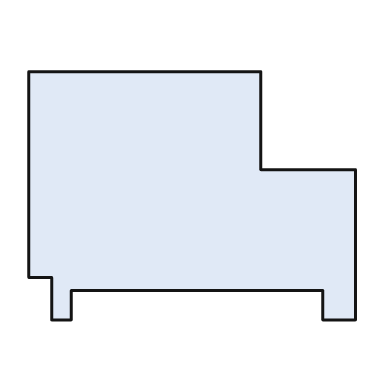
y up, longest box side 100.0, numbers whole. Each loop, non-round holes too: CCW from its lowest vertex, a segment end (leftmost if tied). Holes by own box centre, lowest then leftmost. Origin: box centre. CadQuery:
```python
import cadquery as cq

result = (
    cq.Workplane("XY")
    .moveTo(-43.0, -38.0)
    .lineTo(-37.0, -38.0)
    .lineTo(-37.0, -29.0)
    .lineTo(40.0, -29.0)
    .lineTo(40.0, -38.0)
    .lineTo(50.0, -38.0)
    .lineTo(50.0, 8.0)
    .lineTo(21.0, 8.0)
    .lineTo(21.0, 38.0)
    .lineTo(-50.0, 38.0)
    .lineTo(-50.0, -25.0)
    .lineTo(-43.0, -25.0)
    .close()
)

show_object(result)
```